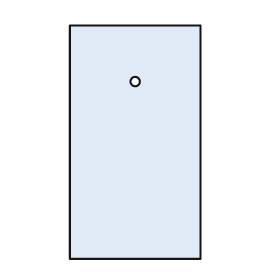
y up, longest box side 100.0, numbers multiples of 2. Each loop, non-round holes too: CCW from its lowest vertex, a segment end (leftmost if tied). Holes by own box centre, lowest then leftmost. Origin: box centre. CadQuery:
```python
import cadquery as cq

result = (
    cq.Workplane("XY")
    .moveTo(-28.0, -50.0)
    .lineTo(28.0, -50.0)
    .lineTo(28.0, 50.0)
    .lineTo(-28.0, 50.0)
    .close()
    .moveTo(0.0, 26.0)
    .circle(2.0)
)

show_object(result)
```